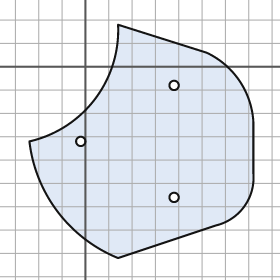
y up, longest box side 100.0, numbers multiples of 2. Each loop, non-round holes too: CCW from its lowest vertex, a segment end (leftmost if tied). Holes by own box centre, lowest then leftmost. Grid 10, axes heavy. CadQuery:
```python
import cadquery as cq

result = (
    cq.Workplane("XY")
    .moveTo(14.0, -82.0)
    .lineTo(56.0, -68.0)
    .threePointArc((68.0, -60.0), (72.0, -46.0))
    .lineTo(72.0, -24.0)
    .threePointArc((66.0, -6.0), (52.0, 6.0))
    .lineTo(14.0, 18.0)
    .threePointArc((4.0, -14.0), (-24.0, -32.0))
    .threePointArc((-12.0, -62.0), (14.0, -82.0))
    .close()
    .moveTo(38.0, -56.0)
    .circle(2.0)
    .moveTo(-2.0, -32.0)
    .circle(2.0)
    .moveTo(38.0, -8.0)
    .circle(2.0)
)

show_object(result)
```